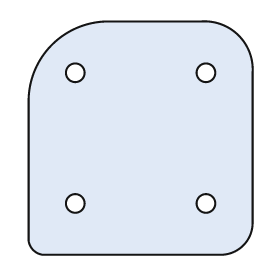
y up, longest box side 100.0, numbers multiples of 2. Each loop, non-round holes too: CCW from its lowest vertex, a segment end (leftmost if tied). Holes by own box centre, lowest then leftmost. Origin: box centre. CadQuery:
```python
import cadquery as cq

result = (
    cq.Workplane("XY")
    .moveTo(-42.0, -50.0)
    .lineTo(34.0, -50.0)
    .threePointArc((44.0, -46.0), (48.0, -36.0))
    .lineTo(48.0, 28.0)
    .threePointArc((42.0, 44.0), (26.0, 50.0))
    .lineTo(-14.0, 50.0)
    .threePointArc((-38.0, 40.0), (-48.0, 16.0))
    .lineTo(-48.0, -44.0)
    .threePointArc((-46.0, -48.0), (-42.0, -50.0))
    .close()
    .moveTo(-28.0, -28.0)
    .circle(4.0)
    .moveTo(28.0, -28.0)
    .circle(4.0)
    .moveTo(-28.0, 28.0)
    .circle(4.0)
    .moveTo(28.0, 28.0)
    .circle(4.0)
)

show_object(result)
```